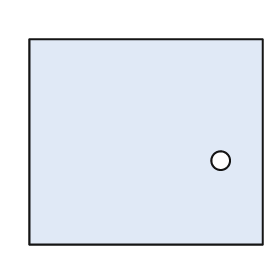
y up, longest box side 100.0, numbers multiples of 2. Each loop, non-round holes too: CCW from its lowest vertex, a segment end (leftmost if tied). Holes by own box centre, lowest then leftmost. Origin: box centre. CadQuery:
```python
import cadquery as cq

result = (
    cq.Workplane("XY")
    .moveTo(-50.0, -44.0)
    .lineTo(50.0, -44.0)
    .lineTo(50.0, 44.0)
    .lineTo(-50.0, 44.0)
    .close()
    .moveTo(32.0, -8.0)
    .circle(4.0)
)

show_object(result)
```